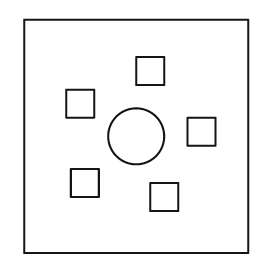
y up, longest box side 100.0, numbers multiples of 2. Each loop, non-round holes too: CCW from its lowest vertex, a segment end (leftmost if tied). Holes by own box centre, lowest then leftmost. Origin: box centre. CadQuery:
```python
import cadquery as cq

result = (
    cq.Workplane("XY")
    .moveTo(-48.0, -50.0)
    .lineTo(48.0, -50.0)
    .lineTo(48.0, 50.0)
    .lineTo(-48.0, 50.0)
    .close()
    .moveTo(6.0, -32.0)
    .lineTo(18.0, -32.0)
    .lineTo(18.0, -20.0)
    .lineTo(6.0, -20.0)
    .close()
    .moveTo(-28.0, -26.0)
    .lineTo(-16.0, -26.0)
    .lineTo(-16.0, -14.0)
    .lineTo(-28.0, -14.0)
    .close()
    .moveTo(0.0, 0.0)
    .circle(12.0)
    .moveTo(22.0, -4.0)
    .lineTo(34.0, -4.0)
    .lineTo(34.0, 8.0)
    .lineTo(22.0, 8.0)
    .close()
    .moveTo(-30.0, 8.0)
    .lineTo(-18.0, 8.0)
    .lineTo(-18.0, 20.0)
    .lineTo(-30.0, 20.0)
    .close()
    .moveTo(0.0, 22.0)
    .lineTo(12.0, 22.0)
    .lineTo(12.0, 34.0)
    .lineTo(0.0, 34.0)
    .close()
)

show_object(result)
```